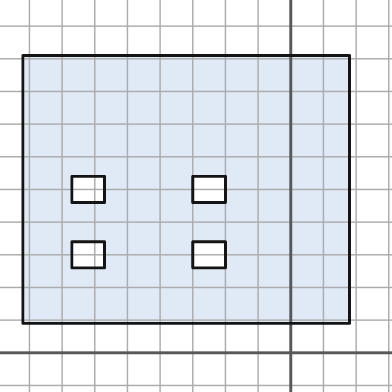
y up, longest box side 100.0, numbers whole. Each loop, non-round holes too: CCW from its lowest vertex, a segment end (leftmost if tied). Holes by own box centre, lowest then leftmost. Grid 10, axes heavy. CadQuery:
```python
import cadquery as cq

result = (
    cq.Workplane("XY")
    .moveTo(-82.0, 9.0)
    .lineTo(18.0, 9.0)
    .lineTo(18.0, 91.0)
    .lineTo(-82.0, 91.0)
    .close()
    .moveTo(-67.0, 26.0)
    .lineTo(-57.0, 26.0)
    .lineTo(-57.0, 34.0)
    .lineTo(-67.0, 34.0)
    .close()
    .moveTo(-30.0, 26.0)
    .lineTo(-20.0, 26.0)
    .lineTo(-20.0, 34.0)
    .lineTo(-30.0, 34.0)
    .close()
    .moveTo(-67.0, 46.0)
    .lineTo(-57.0, 46.0)
    .lineTo(-57.0, 54.0)
    .lineTo(-67.0, 54.0)
    .close()
    .moveTo(-30.0, 46.0)
    .lineTo(-20.0, 46.0)
    .lineTo(-20.0, 54.0)
    .lineTo(-30.0, 54.0)
    .close()
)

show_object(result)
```